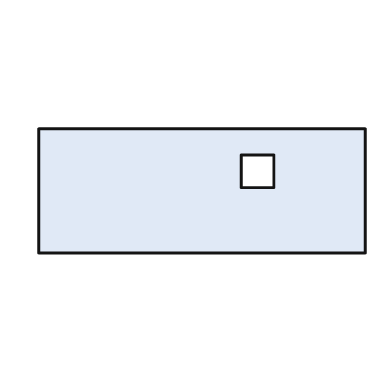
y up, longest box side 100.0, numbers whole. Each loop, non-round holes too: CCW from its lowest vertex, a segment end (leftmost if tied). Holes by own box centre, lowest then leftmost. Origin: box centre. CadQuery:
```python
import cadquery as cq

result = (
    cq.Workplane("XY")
    .moveTo(-50.0, -19.0)
    .lineTo(50.0, -19.0)
    .lineTo(50.0, 19.0)
    .lineTo(-50.0, 19.0)
    .close()
    .moveTo(12.0, 1.0)
    .lineTo(22.0, 1.0)
    .lineTo(22.0, 11.0)
    .lineTo(12.0, 11.0)
    .close()
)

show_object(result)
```